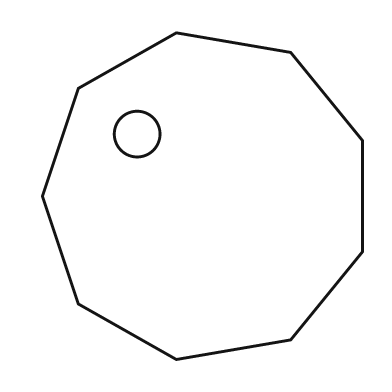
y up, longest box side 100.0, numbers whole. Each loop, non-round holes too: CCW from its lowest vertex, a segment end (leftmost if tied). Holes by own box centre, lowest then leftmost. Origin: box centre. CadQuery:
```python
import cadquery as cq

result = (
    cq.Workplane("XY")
    .moveTo(-8.0, -50.0)
    .lineTo(27.0, -44.0)
    .lineTo(49.0, -17.0)
    .lineTo(49.0, 17.0)
    .lineTo(27.0, 44.0)
    .lineTo(-8.0, 50.0)
    .lineTo(-38.0, 33.0)
    .lineTo(-49.0, 0.0)
    .lineTo(-38.0, -33.0)
    .close()
    .moveTo(-20.0, 19.0)
    .circle(7.0)
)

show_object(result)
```